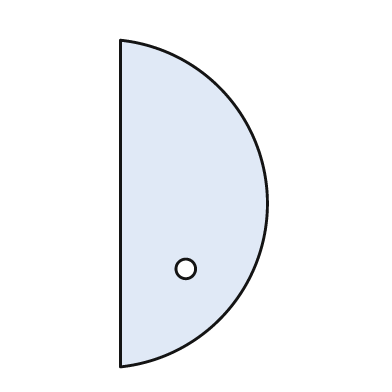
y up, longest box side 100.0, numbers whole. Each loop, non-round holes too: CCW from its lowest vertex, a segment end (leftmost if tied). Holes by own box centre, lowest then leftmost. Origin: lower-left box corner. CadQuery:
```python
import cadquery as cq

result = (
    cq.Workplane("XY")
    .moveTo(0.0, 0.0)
    .threePointArc((45.0, 50.0), (0.0, 100.0))
    .close()
    .moveTo(20.0, 30.0)
    .circle(3.0)
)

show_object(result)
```